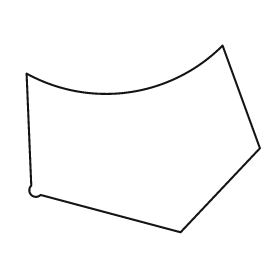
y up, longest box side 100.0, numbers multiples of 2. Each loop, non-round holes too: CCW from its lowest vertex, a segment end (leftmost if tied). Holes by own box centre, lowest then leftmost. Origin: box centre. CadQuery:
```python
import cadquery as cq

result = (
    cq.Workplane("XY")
    .moveTo(16.0, -40.0)
    .lineTo(50.0, -4.0)
    .lineTo(34.0, 40.0)
    .threePointArc((-6.0, 20.0), (-50.0, 28.0))
    .lineTo(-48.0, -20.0)
    .threePointArc((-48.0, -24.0), (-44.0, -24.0))
    .close()
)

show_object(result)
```